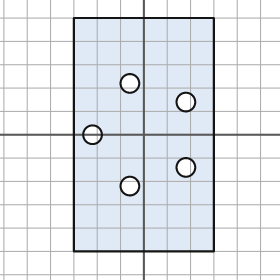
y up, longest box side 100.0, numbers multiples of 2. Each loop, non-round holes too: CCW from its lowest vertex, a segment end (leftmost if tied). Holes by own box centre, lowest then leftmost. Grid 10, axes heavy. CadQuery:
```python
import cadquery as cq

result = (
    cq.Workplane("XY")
    .moveTo(-30.0, -50.0)
    .lineTo(30.0, -50.0)
    .lineTo(30.0, 50.0)
    .lineTo(-30.0, 50.0)
    .close()
    .moveTo(-6.0, -22.0)
    .circle(4.0)
    .moveTo(18.0, -14.0)
    .circle(4.0)
    .moveTo(-22.0, 0.0)
    .circle(4.0)
    .moveTo(18.0, 14.0)
    .circle(4.0)
    .moveTo(-6.0, 22.0)
    .circle(4.0)
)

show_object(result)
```